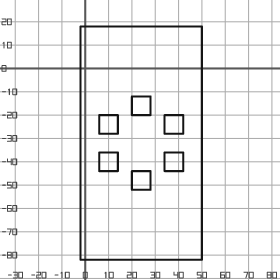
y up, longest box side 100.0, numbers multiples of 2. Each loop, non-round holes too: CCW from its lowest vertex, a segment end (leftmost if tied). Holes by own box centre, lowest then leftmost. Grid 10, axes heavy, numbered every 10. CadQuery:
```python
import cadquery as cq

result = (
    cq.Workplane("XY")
    .moveTo(-2.0, -82.0)
    .lineTo(50.0, -82.0)
    .lineTo(50.0, 18.0)
    .lineTo(-2.0, 18.0)
    .close()
    .moveTo(20.0, -52.0)
    .lineTo(28.0, -52.0)
    .lineTo(28.0, -44.0)
    .lineTo(20.0, -44.0)
    .close()
    .moveTo(6.0, -44.0)
    .lineTo(14.0, -44.0)
    .lineTo(14.0, -36.0)
    .lineTo(6.0, -36.0)
    .close()
    .moveTo(34.0, -44.0)
    .lineTo(42.0, -44.0)
    .lineTo(42.0, -36.0)
    .lineTo(34.0, -36.0)
    .close()
    .moveTo(6.0, -28.0)
    .lineTo(14.0, -28.0)
    .lineTo(14.0, -20.0)
    .lineTo(6.0, -20.0)
    .close()
    .moveTo(34.0, -28.0)
    .lineTo(42.0, -28.0)
    .lineTo(42.0, -20.0)
    .lineTo(34.0, -20.0)
    .close()
    .moveTo(20.0, -20.0)
    .lineTo(28.0, -20.0)
    .lineTo(28.0, -12.0)
    .lineTo(20.0, -12.0)
    .close()
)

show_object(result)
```